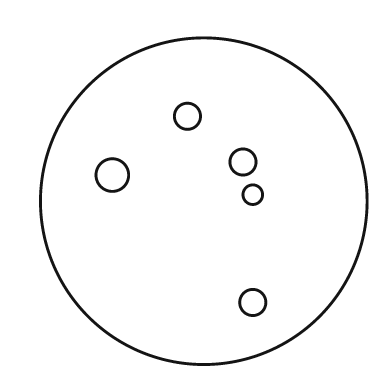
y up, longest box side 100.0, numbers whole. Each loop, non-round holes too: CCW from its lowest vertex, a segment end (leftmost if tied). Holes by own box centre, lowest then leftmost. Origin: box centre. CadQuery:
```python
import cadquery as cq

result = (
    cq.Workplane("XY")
    .moveTo(0.0, 0.0)
    .circle(50.0)
    .moveTo(15.0, -31.0)
    .circle(4.0)
    .moveTo(15.0, 2.0)
    .circle(3.0)
    .moveTo(-28.0, 8.0)
    .circle(5.0)
    .moveTo(12.0, 12.0)
    .circle(4.0)
    .moveTo(-5.0, 26.0)
    .circle(4.0)
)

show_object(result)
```